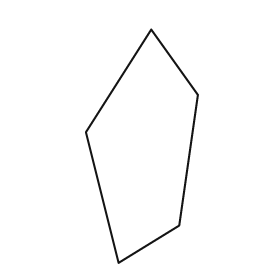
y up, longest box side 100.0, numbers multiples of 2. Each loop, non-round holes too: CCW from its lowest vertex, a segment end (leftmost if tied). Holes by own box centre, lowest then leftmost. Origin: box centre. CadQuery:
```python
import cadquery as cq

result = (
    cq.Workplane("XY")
    .moveTo(-10.0, -50.0)
    .lineTo(16.0, -34.0)
    .lineTo(24.0, 22.0)
    .lineTo(4.0, 50.0)
    .lineTo(-24.0, 6.0)
    .close()
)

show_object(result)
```